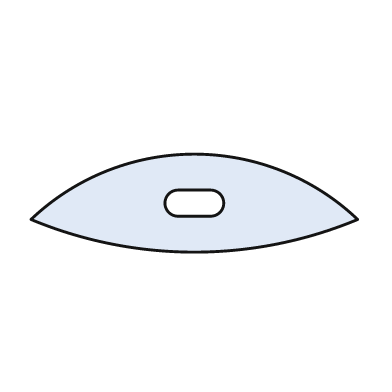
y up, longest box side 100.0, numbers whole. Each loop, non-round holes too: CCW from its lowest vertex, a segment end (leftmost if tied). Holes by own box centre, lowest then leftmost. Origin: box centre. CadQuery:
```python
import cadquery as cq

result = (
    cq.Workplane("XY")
    .moveTo(-50.0, -5.0)
    .threePointArc((0.0, -15.0), (50.0, -5.0))
    .threePointArc((0.0, 15.0), (-50.0, -5.0))
    .close()
    .moveTo(-5.0, -4.0)
    .lineTo(5.0, -4.0)
    .threePointArc((9.0, 0.0), (5.0, 4.0))
    .lineTo(-5.0, 4.0)
    .threePointArc((-9.0, 0.0), (-5.0, -4.0))
    .close()
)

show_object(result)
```